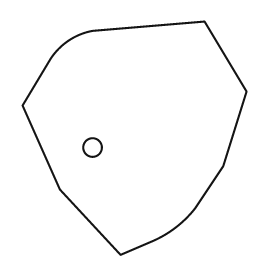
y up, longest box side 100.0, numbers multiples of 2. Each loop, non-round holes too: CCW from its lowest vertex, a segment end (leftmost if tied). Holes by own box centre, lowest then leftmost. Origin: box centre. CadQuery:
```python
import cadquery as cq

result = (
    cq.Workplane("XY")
    .moveTo(-6.0, -50.0)
    .lineTo(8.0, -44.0)
    .threePointArc((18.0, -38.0), (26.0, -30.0))
    .lineTo(38.0, -12.0)
    .lineTo(48.0, 20.0)
    .lineTo(30.0, 50.0)
    .lineTo(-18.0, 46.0)
    .threePointArc((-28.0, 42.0), (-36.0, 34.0))
    .lineTo(-48.0, 14.0)
    .lineTo(-32.0, -22.0)
    .close()
    .moveTo(-18.0, -4.0)
    .circle(4.0)
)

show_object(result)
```